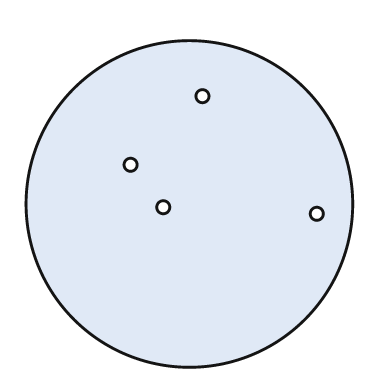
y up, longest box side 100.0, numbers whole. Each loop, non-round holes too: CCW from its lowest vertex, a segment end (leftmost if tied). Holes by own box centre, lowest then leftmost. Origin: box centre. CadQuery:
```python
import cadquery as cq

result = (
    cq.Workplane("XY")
    .moveTo(0.0, 0.0)
    .circle(50.0)
    .moveTo(39.0, -3.0)
    .circle(2.0)
    .moveTo(-8.0, -1.0)
    .circle(2.0)
    .moveTo(-18.0, 12.0)
    .circle(2.0)
    .moveTo(4.0, 33.0)
    .circle(2.0)
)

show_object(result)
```